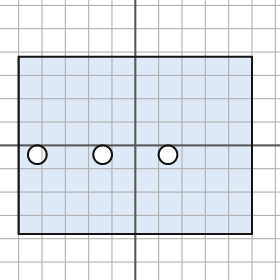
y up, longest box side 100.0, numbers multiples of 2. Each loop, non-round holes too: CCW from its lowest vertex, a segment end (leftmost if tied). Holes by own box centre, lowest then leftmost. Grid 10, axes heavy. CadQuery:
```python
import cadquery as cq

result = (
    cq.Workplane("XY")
    .moveTo(-50.0, -38.0)
    .lineTo(50.0, -38.0)
    .lineTo(50.0, 38.0)
    .lineTo(-50.0, 38.0)
    .close()
    .moveTo(-42.0, -4.0)
    .circle(4.0)
    .moveTo(-14.0, -4.0)
    .circle(4.0)
    .moveTo(14.0, -4.0)
    .circle(4.0)
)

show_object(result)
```